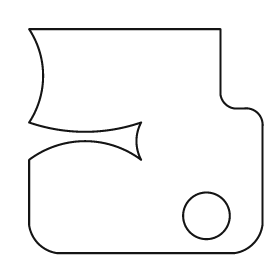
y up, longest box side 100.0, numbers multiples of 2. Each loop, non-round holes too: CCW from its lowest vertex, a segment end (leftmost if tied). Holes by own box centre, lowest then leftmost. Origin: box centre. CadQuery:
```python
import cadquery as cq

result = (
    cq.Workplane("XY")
    .moveTo(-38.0, -48.0)
    .lineTo(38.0, -48.0)
    .threePointArc((46.0, -44.0), (50.0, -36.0))
    .lineTo(50.0, 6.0)
    .threePointArc((48.0, 12.0), (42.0, 14.0))
    .lineTo(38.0, 14.0)
    .threePointArc((34.0, 16.0), (32.0, 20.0))
    .lineTo(32.0, 48.0)
    .lineTo(-50.0, 48.0)
    .threePointArc((-44.0, 28.0), (-50.0, 8.0))
    .threePointArc((-26.0, 4.0), (-2.0, 8.0))
    .threePointArc((-4.0, 0.0), (-2.0, -8.0))
    .threePointArc((-26.0, 0.0), (-50.0, -8.0))
    .lineTo(-50.0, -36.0)
    .threePointArc((-46.0, -44.0), (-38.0, -48.0))
    .close()
    .moveTo(26.0, -32.0)
    .circle(10.0)
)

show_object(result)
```